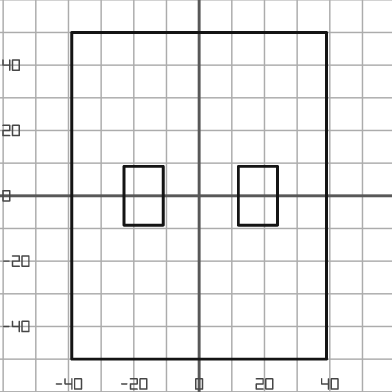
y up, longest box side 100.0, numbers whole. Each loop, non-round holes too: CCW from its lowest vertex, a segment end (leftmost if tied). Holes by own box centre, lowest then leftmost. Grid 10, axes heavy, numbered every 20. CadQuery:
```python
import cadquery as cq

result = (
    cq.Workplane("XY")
    .moveTo(-39.0, -50.0)
    .lineTo(39.0, -50.0)
    .lineTo(39.0, 50.0)
    .lineTo(-39.0, 50.0)
    .close()
    .moveTo(-23.0, -9.0)
    .lineTo(-11.0, -9.0)
    .lineTo(-11.0, 9.0)
    .lineTo(-23.0, 9.0)
    .close()
    .moveTo(12.0, -9.0)
    .lineTo(24.0, -9.0)
    .lineTo(24.0, 9.0)
    .lineTo(12.0, 9.0)
    .close()
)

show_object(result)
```